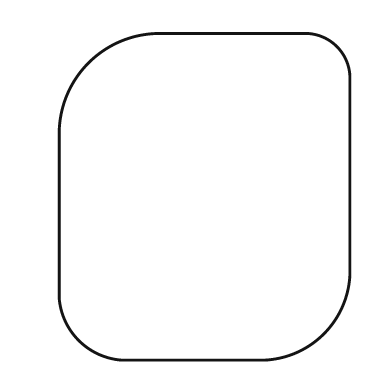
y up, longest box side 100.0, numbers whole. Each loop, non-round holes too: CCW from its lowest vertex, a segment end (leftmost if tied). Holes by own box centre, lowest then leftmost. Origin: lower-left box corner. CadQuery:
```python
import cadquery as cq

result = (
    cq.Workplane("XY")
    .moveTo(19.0, 0.0)
    .lineTo(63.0, 0.0)
    .threePointArc((81.0, 8.0), (89.0, 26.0))
    .lineTo(89.0, 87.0)
    .threePointArc((85.0, 96.0), (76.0, 100.0))
    .lineTo(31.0, 100.0)
    .threePointArc((9.0, 91.0), (0.0, 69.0))
    .lineTo(0.0, 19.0)
    .threePointArc((6.0, 6.0), (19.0, 0.0))
    .close()
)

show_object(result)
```